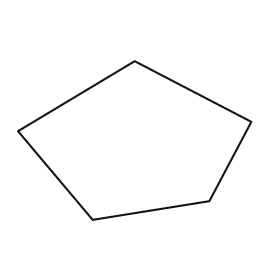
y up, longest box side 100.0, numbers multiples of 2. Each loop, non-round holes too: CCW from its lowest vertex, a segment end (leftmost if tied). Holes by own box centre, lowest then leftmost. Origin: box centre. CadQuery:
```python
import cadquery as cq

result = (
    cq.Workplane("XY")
    .moveTo(-18.0, -34.0)
    .lineTo(32.0, -26.0)
    .lineTo(50.0, 8.0)
    .lineTo(0.0, 34.0)
    .lineTo(-50.0, 4.0)
    .close()
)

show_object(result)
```